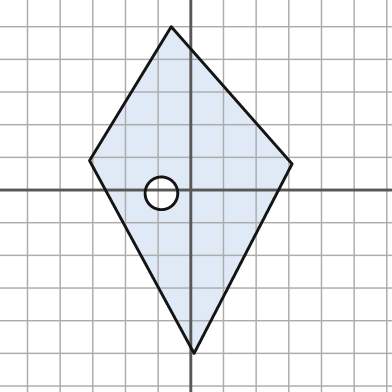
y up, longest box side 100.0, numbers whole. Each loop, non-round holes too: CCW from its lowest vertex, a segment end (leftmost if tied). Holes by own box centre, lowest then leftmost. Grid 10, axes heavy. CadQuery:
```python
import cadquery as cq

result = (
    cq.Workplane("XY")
    .moveTo(1.0, -50.0)
    .lineTo(31.0, 8.0)
    .lineTo(-6.0, 50.0)
    .lineTo(-31.0, 9.0)
    .close()
    .moveTo(-9.0, -1.0)
    .circle(5.0)
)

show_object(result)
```